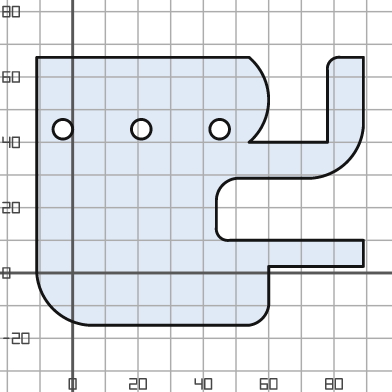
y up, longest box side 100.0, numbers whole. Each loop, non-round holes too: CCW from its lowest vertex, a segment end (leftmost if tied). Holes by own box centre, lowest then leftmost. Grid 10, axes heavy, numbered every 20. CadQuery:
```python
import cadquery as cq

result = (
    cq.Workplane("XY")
    .moveTo(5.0, -16.0)
    .lineTo(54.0, -16.0)
    .threePointArc((58.0, -14.0), (60.0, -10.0))
    .lineTo(60.0, 2.0)
    .lineTo(89.0, 2.0)
    .lineTo(89.0, 10.0)
    .lineTo(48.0, 10.0)
    .threePointArc((45.0, 11.0), (44.0, 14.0))
    .lineTo(44.0, 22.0)
    .threePointArc((46.0, 27.0), (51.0, 29.0))
    .lineTo(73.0, 29.0)
    .threePointArc((84.0, 34.0), (89.0, 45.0))
    .lineTo(89.0, 66.0)
    .lineTo(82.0, 66.0)
    .threePointArc((79.0, 65.0), (78.0, 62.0))
    .lineTo(78.0, 40.0)
    .lineTo(54.0, 40.0)
    .threePointArc((60.0, 53.0), (54.0, 66.0))
    .lineTo(-11.0, 66.0)
    .lineTo(-11.0, 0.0)
    .threePointArc((-6.0, -11.0), (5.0, -16.0))
    .close()
    .moveTo(-3.0, 44.0)
    .circle(3.0)
    .moveTo(21.0, 44.0)
    .circle(3.0)
    .moveTo(45.0, 44.0)
    .circle(3.0)
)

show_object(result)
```